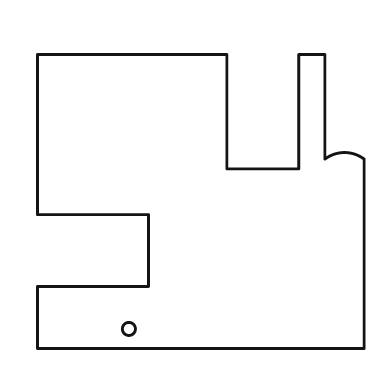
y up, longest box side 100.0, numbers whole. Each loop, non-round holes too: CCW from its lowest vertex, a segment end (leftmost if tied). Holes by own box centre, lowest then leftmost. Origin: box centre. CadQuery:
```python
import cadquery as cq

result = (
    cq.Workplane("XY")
    .moveTo(-50.0, -45.0)
    .lineTo(50.0, -45.0)
    .lineTo(50.0, 13.0)
    .threePointArc((44.0, 15.0), (38.0, 13.0))
    .lineTo(38.0, 45.0)
    .lineTo(30.0, 45.0)
    .lineTo(30.0, 10.0)
    .lineTo(8.0, 10.0)
    .lineTo(8.0, 45.0)
    .lineTo(-50.0, 45.0)
    .lineTo(-50.0, -4.0)
    .lineTo(-16.0, -4.0)
    .lineTo(-16.0, -26.0)
    .lineTo(-50.0, -26.0)
    .close()
    .moveTo(-22.0, -39.0)
    .circle(2.0)
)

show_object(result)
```